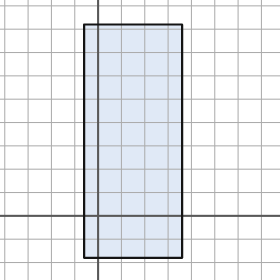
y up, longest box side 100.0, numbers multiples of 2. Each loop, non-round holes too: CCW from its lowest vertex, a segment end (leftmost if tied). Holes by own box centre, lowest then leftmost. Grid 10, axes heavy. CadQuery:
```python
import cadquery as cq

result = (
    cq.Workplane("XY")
    .moveTo(-6.0, -18.0)
    .lineTo(36.0, -18.0)
    .lineTo(36.0, 82.0)
    .lineTo(-6.0, 82.0)
    .close()
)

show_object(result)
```